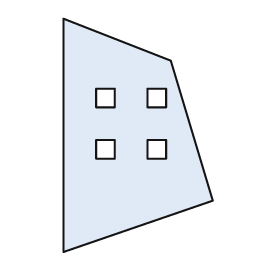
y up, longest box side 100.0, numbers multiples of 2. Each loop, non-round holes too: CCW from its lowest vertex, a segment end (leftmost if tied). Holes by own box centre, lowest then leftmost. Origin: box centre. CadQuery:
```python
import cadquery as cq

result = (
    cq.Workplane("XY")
    .moveTo(-32.0, -50.0)
    .lineTo(32.0, -28.0)
    .lineTo(14.0, 32.0)
    .lineTo(-32.0, 50.0)
    .close()
    .moveTo(-18.0, -10.0)
    .lineTo(-10.0, -10.0)
    .lineTo(-10.0, -2.0)
    .lineTo(-18.0, -2.0)
    .close()
    .moveTo(4.0, -10.0)
    .lineTo(12.0, -10.0)
    .lineTo(12.0, -2.0)
    .lineTo(4.0, -2.0)
    .close()
    .moveTo(-18.0, 12.0)
    .lineTo(-10.0, 12.0)
    .lineTo(-10.0, 20.0)
    .lineTo(-18.0, 20.0)
    .close()
    .moveTo(4.0, 12.0)
    .lineTo(12.0, 12.0)
    .lineTo(12.0, 20.0)
    .lineTo(4.0, 20.0)
    .close()
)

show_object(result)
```